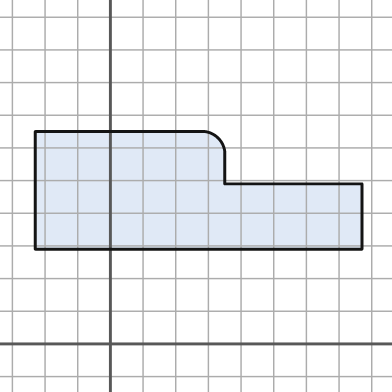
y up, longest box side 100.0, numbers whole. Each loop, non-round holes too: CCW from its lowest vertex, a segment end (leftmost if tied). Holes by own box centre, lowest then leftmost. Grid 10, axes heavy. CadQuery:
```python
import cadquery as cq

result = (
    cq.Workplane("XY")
    .moveTo(-23.0, 29.0)
    .lineTo(77.0, 29.0)
    .lineTo(77.0, 49.0)
    .lineTo(35.0, 49.0)
    .lineTo(35.0, 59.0)
    .threePointArc((33.0, 63.0), (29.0, 65.0))
    .lineTo(-23.0, 65.0)
    .close()
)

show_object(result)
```